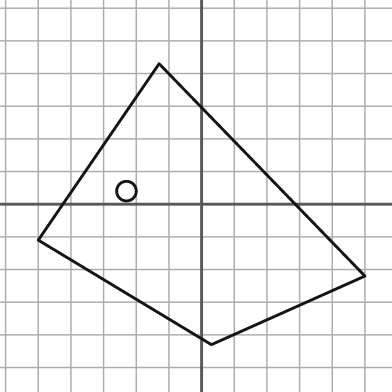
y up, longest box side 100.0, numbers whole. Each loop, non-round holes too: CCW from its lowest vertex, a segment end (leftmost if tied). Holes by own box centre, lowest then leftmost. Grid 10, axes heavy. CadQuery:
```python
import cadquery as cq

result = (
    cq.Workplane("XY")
    .moveTo(3.0, -43.0)
    .lineTo(50.0, -22.0)
    .lineTo(-13.0, 43.0)
    .lineTo(-50.0, -11.0)
    .close()
    .moveTo(-23.0, 4.0)
    .circle(3.0)
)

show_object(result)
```